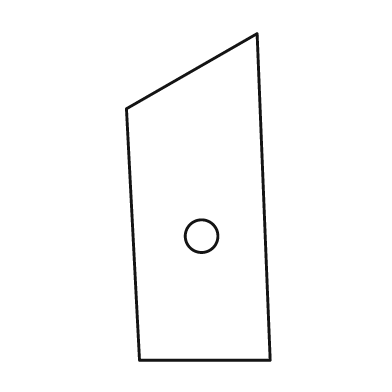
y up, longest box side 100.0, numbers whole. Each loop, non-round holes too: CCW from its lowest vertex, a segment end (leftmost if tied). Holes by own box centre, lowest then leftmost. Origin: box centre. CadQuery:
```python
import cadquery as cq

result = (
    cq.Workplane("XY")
    .moveTo(-18.0, -50.0)
    .lineTo(22.0, -50.0)
    .lineTo(18.0, 50.0)
    .lineTo(-22.0, 27.0)
    .close()
    .moveTo(1.0, -12.0)
    .circle(5.0)
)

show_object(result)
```